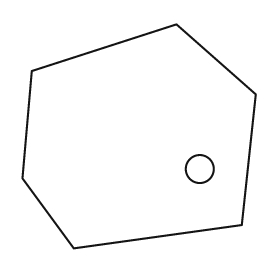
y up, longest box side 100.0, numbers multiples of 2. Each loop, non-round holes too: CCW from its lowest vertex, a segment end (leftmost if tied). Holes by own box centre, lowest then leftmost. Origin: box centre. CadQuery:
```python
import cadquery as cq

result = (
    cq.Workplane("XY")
    .moveTo(-28.0, -48.0)
    .lineTo(44.0, -38.0)
    .lineTo(50.0, 18.0)
    .lineTo(16.0, 48.0)
    .lineTo(-46.0, 28.0)
    .lineTo(-50.0, -18.0)
    .close()
    .moveTo(26.0, -14.0)
    .circle(6.0)
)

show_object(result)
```